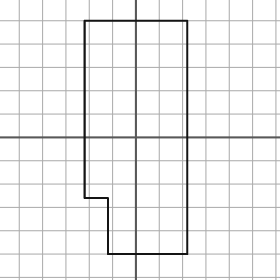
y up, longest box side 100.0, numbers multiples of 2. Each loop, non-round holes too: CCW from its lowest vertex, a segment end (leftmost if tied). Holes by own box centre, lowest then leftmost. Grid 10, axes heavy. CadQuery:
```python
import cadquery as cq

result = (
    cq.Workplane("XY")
    .moveTo(-12.0, -50.0)
    .lineTo(22.0, -50.0)
    .lineTo(22.0, 50.0)
    .lineTo(-22.0, 50.0)
    .lineTo(-22.0, -26.0)
    .lineTo(-12.0, -26.0)
    .close()
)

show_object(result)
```